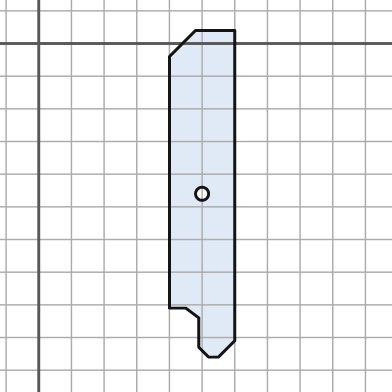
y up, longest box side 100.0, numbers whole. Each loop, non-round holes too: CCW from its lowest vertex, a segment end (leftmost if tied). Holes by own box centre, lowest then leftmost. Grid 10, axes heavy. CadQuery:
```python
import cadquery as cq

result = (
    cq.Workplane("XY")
    .moveTo(52.0, -96.0)
    .lineTo(55.0, -96.0)
    .lineTo(60.0, -91.0)
    .lineTo(60.0, 4.0)
    .lineTo(48.0, 4.0)
    .lineTo(40.0, -4.0)
    .lineTo(40.0, -81.0)
    .lineTo(45.0, -81.0)
    .lineTo(49.0, -84.0)
    .lineTo(49.0, -93.0)
    .close()
    .moveTo(50.0, -46.0)
    .circle(2.0)
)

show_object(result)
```